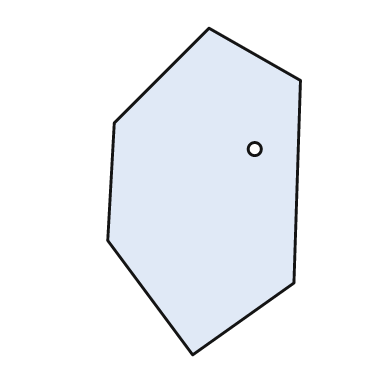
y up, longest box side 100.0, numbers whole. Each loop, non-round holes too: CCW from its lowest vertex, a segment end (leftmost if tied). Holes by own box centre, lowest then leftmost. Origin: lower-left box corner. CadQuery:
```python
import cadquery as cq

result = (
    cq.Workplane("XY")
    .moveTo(26.0, 0.0)
    .lineTo(57.0, 22.0)
    .lineTo(59.0, 84.0)
    .lineTo(31.0, 100.0)
    .lineTo(2.0, 71.0)
    .lineTo(0.0, 35.0)
    .close()
    .moveTo(45.0, 63.0)
    .circle(2.0)
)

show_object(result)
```